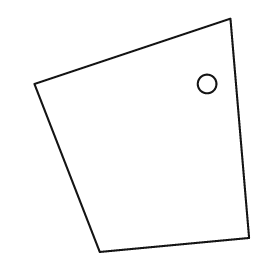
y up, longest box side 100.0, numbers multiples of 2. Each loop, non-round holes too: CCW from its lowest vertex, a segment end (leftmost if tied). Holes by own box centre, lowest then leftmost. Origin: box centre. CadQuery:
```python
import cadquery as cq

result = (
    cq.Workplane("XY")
    .moveTo(-18.0, -50.0)
    .lineTo(46.0, -44.0)
    .lineTo(38.0, 50.0)
    .lineTo(-46.0, 22.0)
    .close()
    .moveTo(28.0, 22.0)
    .circle(4.0)
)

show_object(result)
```